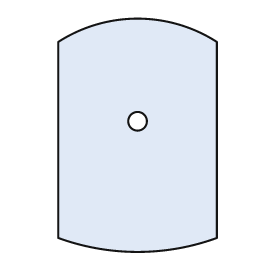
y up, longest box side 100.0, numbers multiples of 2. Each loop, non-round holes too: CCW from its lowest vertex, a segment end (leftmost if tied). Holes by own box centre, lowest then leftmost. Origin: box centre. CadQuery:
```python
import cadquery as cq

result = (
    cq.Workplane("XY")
    .moveTo(-34.0, -44.0)
    .threePointArc((0.0, -50.0), (34.0, -44.0))
    .lineTo(34.0, 40.0)
    .threePointArc((0.0, 50.0), (-34.0, 40.0))
    .close()
    .moveTo(0.0, 6.0)
    .circle(4.0)
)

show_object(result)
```